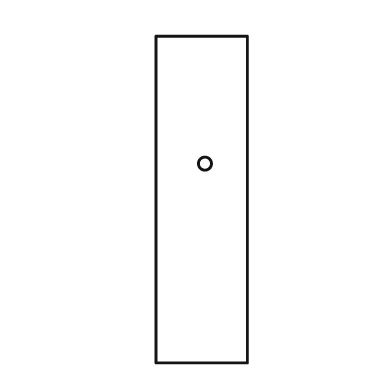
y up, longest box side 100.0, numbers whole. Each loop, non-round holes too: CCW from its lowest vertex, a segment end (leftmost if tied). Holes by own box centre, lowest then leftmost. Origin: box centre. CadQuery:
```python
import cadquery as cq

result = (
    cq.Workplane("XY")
    .moveTo(-14.0, -50.0)
    .lineTo(14.0, -50.0)
    .lineTo(14.0, 50.0)
    .lineTo(-14.0, 50.0)
    .close()
    .moveTo(1.0, 11.0)
    .circle(2.0)
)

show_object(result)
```